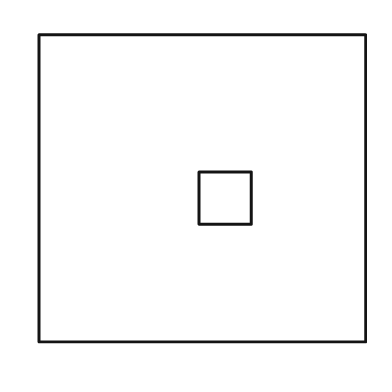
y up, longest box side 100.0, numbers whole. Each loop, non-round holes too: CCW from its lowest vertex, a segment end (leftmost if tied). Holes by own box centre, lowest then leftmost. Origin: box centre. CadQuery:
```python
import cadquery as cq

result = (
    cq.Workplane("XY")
    .moveTo(-50.0, -47.0)
    .lineTo(50.0, -47.0)
    .lineTo(50.0, 47.0)
    .lineTo(-50.0, 47.0)
    .close()
    .moveTo(-1.0, -11.0)
    .lineTo(15.0, -11.0)
    .lineTo(15.0, 5.0)
    .lineTo(-1.0, 5.0)
    .close()
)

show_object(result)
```